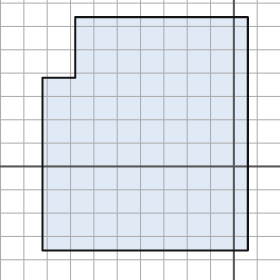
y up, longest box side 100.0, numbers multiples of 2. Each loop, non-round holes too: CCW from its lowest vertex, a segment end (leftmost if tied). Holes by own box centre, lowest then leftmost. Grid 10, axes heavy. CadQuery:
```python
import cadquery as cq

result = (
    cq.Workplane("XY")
    .moveTo(-82.0, -36.0)
    .lineTo(6.0, -36.0)
    .lineTo(6.0, 64.0)
    .lineTo(-68.0, 64.0)
    .lineTo(-68.0, 38.0)
    .lineTo(-82.0, 38.0)
    .close()
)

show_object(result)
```